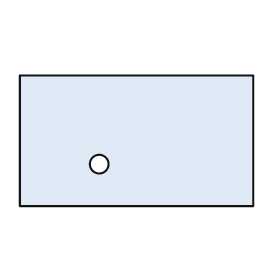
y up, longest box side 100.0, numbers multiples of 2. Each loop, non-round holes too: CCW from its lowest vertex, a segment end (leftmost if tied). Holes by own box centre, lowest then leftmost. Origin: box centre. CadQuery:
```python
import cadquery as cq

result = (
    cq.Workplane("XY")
    .moveTo(-50.0, -28.0)
    .lineTo(50.0, -28.0)
    .lineTo(50.0, 28.0)
    .lineTo(-50.0, 28.0)
    .close()
    .moveTo(-16.0, -10.0)
    .circle(4.0)
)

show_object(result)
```